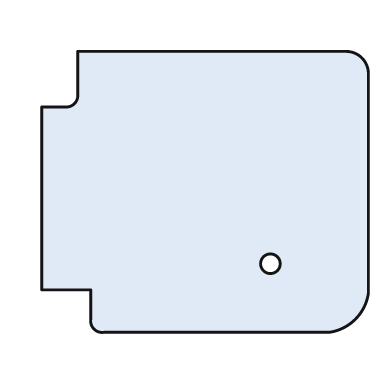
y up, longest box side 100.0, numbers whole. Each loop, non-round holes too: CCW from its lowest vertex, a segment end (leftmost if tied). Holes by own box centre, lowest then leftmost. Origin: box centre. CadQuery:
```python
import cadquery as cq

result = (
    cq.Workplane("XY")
    .moveTo(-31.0, -43.0)
    .lineTo(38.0, -43.0)
    .threePointArc((46.0, -39.0), (50.0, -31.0))
    .lineTo(50.0, 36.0)
    .threePointArc((48.0, 41.0), (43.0, 43.0))
    .lineTo(-39.0, 43.0)
    .lineTo(-39.0, 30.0)
    .threePointArc((-40.0, 27.0), (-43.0, 26.0))
    .lineTo(-50.0, 26.0)
    .lineTo(-50.0, -30.0)
    .lineTo(-35.0, -30.0)
    .lineTo(-35.0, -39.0)
    .threePointArc((-34.0, -42.0), (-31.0, -43.0))
    .close()
    .moveTo(20.0, -22.0)
    .circle(3.0)
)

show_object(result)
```